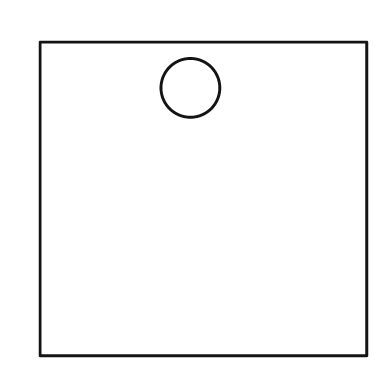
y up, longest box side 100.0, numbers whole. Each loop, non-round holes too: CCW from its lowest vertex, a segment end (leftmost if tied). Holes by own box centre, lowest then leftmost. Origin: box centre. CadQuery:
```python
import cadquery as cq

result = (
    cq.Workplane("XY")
    .moveTo(-50.0, -48.0)
    .lineTo(50.0, -48.0)
    .lineTo(50.0, 48.0)
    .lineTo(-50.0, 48.0)
    .close()
    .moveTo(-4.0, 34.0)
    .circle(9.0)
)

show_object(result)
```